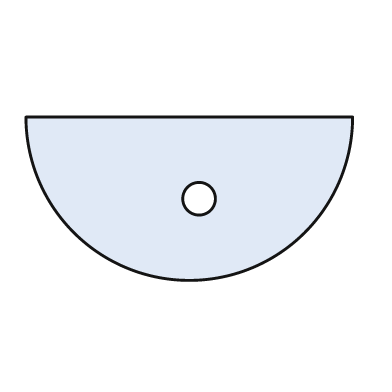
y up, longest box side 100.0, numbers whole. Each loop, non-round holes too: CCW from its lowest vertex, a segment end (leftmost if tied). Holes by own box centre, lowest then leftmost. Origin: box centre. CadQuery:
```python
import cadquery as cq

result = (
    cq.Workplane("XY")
    .moveTo(-50.0, 25.0)
    .threePointArc((0.0, -25.0), (50.0, 25.0))
    .close()
    .moveTo(3.0, 0.0)
    .circle(5.0)
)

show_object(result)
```